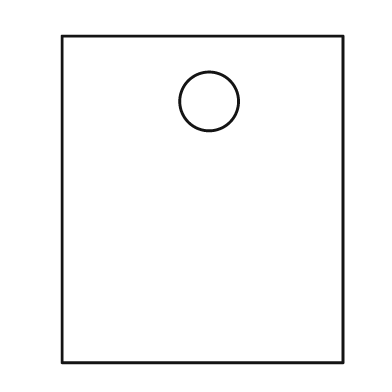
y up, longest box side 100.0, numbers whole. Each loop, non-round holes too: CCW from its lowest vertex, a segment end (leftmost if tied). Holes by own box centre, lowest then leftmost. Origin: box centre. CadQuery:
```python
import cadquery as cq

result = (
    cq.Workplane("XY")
    .moveTo(-43.0, -50.0)
    .lineTo(43.0, -50.0)
    .lineTo(43.0, 50.0)
    .lineTo(-43.0, 50.0)
    .close()
    .moveTo(2.0, 30.0)
    .circle(9.0)
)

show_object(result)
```